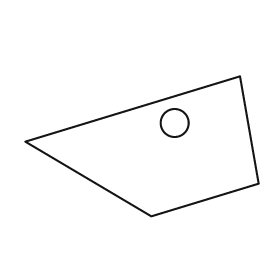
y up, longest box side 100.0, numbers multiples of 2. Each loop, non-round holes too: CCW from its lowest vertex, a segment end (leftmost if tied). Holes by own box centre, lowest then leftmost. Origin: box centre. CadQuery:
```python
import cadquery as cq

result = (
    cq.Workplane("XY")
    .moveTo(4.0, -30.0)
    .lineTo(50.0, -16.0)
    .lineTo(42.0, 30.0)
    .lineTo(-50.0, 2.0)
    .close()
    .moveTo(14.0, 10.0)
    .circle(6.0)
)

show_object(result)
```